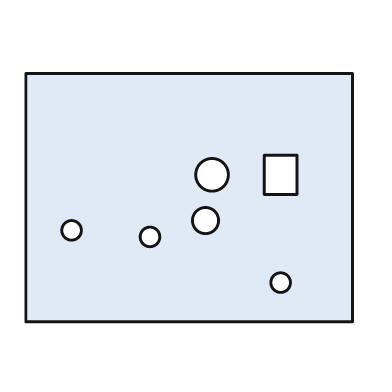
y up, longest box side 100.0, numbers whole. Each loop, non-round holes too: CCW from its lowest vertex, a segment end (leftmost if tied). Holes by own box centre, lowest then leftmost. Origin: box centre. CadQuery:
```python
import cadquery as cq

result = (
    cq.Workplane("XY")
    .moveTo(-50.0, -38.0)
    .lineTo(50.0, -38.0)
    .lineTo(50.0, 38.0)
    .lineTo(-50.0, 38.0)
    .close()
    .moveTo(28.0, -26.0)
    .circle(3.0)
    .moveTo(-12.0, -12.0)
    .circle(3.0)
    .moveTo(-36.0, -10.0)
    .circle(3.0)
    .moveTo(5.0, -7.0)
    .circle(4.0)
    .moveTo(7.0, 7.0)
    .circle(5.0)
    .moveTo(23.0, 1.0)
    .lineTo(33.0, 1.0)
    .lineTo(33.0, 13.0)
    .lineTo(23.0, 13.0)
    .close()
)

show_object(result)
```